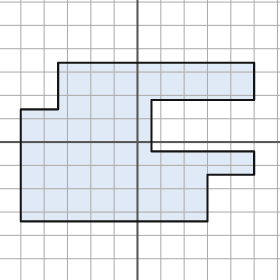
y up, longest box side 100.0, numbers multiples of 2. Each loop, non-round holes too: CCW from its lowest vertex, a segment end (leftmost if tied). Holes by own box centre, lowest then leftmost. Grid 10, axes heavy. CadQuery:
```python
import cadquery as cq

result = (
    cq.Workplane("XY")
    .moveTo(-50.0, -34.0)
    .lineTo(30.0, -34.0)
    .lineTo(30.0, -14.0)
    .lineTo(50.0, -14.0)
    .lineTo(50.0, -4.0)
    .lineTo(6.0, -4.0)
    .lineTo(6.0, 18.0)
    .lineTo(50.0, 18.0)
    .lineTo(50.0, 34.0)
    .lineTo(-34.0, 34.0)
    .lineTo(-34.0, 14.0)
    .lineTo(-50.0, 14.0)
    .close()
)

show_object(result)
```